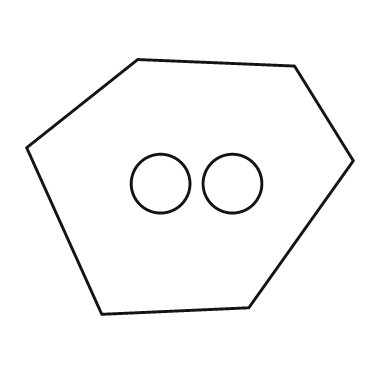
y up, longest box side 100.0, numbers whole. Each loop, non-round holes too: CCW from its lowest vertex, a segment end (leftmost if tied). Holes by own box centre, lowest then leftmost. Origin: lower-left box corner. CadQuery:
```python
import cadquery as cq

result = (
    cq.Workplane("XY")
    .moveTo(23.0, 0.0)
    .lineTo(68.0, 2.0)
    .lineTo(100.0, 47.0)
    .lineTo(82.0, 76.0)
    .lineTo(34.0, 78.0)
    .lineTo(0.0, 51.0)
    .close()
    .moveTo(41.0, 40.0)
    .circle(9.0)
    .moveTo(63.0, 40.0)
    .circle(9.0)
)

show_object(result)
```